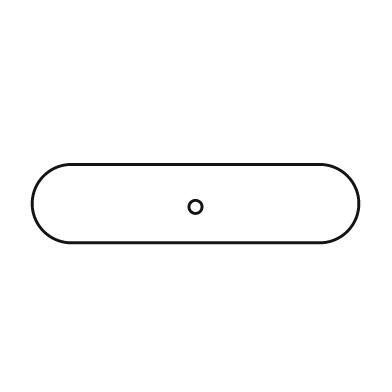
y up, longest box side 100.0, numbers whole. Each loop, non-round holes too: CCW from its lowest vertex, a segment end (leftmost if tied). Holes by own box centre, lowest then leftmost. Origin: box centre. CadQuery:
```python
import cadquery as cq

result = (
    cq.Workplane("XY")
    .moveTo(-38.0, -12.0)
    .lineTo(38.0, -12.0)
    .threePointArc((50.0, 0.0), (38.0, 12.0))
    .lineTo(-38.0, 12.0)
    .threePointArc((-50.0, 0.0), (-38.0, -12.0))
    .close()
    .moveTo(0.0, -1.0)
    .circle(2.0)
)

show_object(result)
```